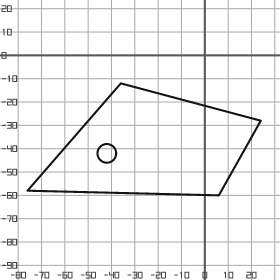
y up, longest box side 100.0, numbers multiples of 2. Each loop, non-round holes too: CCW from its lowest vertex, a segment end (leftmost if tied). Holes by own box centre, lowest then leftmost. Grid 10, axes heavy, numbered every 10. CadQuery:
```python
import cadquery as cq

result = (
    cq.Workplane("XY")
    .moveTo(6.0, -60.0)
    .lineTo(24.0, -28.0)
    .lineTo(-36.0, -12.0)
    .lineTo(-76.0, -58.0)
    .close()
    .moveTo(-42.0, -42.0)
    .circle(4.0)
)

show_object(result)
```